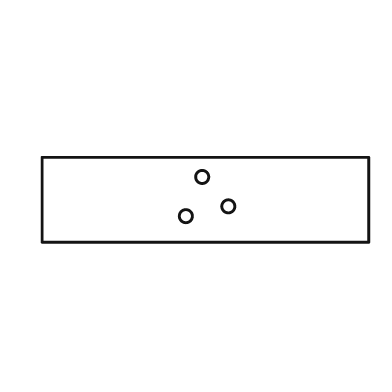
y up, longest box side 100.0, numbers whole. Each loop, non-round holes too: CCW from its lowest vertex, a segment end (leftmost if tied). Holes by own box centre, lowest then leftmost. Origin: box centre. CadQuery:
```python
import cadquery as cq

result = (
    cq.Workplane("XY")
    .moveTo(-50.0, -13.0)
    .lineTo(50.0, -13.0)
    .lineTo(50.0, 13.0)
    .lineTo(-50.0, 13.0)
    .close()
    .moveTo(-6.0, -5.0)
    .circle(2.0)
    .moveTo(7.0, -2.0)
    .circle(2.0)
    .moveTo(-1.0, 7.0)
    .circle(2.0)
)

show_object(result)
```